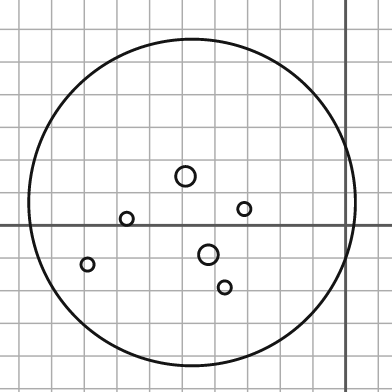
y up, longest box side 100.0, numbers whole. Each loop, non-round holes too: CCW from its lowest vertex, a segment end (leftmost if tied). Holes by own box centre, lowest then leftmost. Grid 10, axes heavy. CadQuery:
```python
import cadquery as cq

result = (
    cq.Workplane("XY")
    .moveTo(-47.0, 7.0)
    .circle(50.0)
    .moveTo(-37.0, -19.0)
    .circle(2.0)
    .moveTo(-79.0, -12.0)
    .circle(2.0)
    .moveTo(-42.0, -9.0)
    .circle(3.0)
    .moveTo(-67.0, 2.0)
    .circle(2.0)
    .moveTo(-31.0, 5.0)
    .circle(2.0)
    .moveTo(-49.0, 15.0)
    .circle(3.0)
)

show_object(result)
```